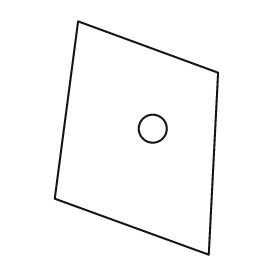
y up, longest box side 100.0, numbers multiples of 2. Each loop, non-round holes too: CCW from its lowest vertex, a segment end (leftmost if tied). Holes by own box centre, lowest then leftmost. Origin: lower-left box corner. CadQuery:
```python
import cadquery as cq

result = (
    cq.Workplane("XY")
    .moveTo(66.0, 0.0)
    .lineTo(70.0, 78.0)
    .lineTo(10.0, 100.0)
    .lineTo(0.0, 24.0)
    .close()
    .moveTo(42.0, 54.0)
    .circle(6.0)
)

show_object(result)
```